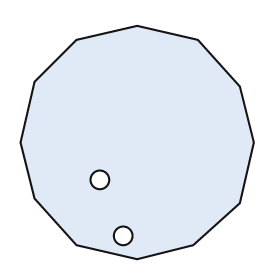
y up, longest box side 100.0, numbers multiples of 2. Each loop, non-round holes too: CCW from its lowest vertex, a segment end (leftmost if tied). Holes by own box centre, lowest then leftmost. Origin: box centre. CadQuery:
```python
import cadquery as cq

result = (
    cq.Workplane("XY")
    .moveTo(0.0, -50.0)
    .lineTo(24.0, -44.0)
    .lineTo(44.0, -26.0)
    .lineTo(50.0, 0.0)
    .lineTo(44.0, 24.0)
    .lineTo(26.0, 44.0)
    .lineTo(0.0, 50.0)
    .lineTo(-26.0, 44.0)
    .lineTo(-44.0, 26.0)
    .lineTo(-50.0, 0.0)
    .lineTo(-44.0, -24.0)
    .lineTo(-26.0, -44.0)
    .close()
    .moveTo(-6.0, -40.0)
    .circle(4.0)
    .moveTo(-16.0, -16.0)
    .circle(4.0)
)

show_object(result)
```